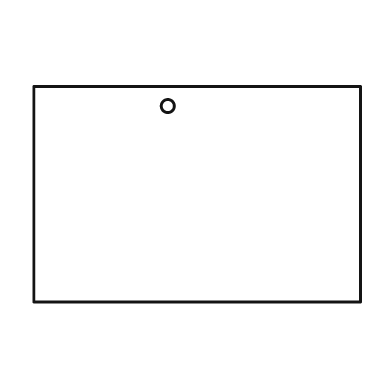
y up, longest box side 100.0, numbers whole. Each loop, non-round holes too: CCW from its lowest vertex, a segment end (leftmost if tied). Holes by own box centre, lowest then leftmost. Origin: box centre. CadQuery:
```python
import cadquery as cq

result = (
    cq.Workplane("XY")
    .moveTo(-50.0, -33.0)
    .lineTo(50.0, -33.0)
    .lineTo(50.0, 33.0)
    .lineTo(-50.0, 33.0)
    .close()
    .moveTo(-9.0, 27.0)
    .circle(2.0)
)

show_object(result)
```